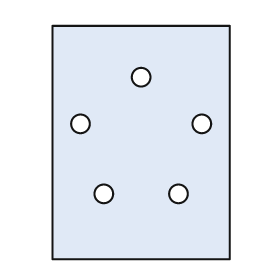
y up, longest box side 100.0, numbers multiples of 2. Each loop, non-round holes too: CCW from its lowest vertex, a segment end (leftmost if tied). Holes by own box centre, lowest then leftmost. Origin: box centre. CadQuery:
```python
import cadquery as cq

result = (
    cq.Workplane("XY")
    .moveTo(-38.0, -50.0)
    .lineTo(38.0, -50.0)
    .lineTo(38.0, 50.0)
    .lineTo(-38.0, 50.0)
    .close()
    .moveTo(-16.0, -22.0)
    .circle(4.0)
    .moveTo(16.0, -22.0)
    .circle(4.0)
    .moveTo(-26.0, 8.0)
    .circle(4.0)
    .moveTo(26.0, 8.0)
    .circle(4.0)
    .moveTo(0.0, 28.0)
    .circle(4.0)
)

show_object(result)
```